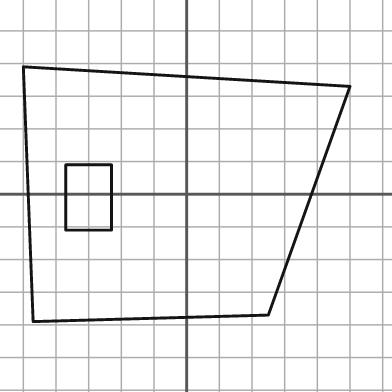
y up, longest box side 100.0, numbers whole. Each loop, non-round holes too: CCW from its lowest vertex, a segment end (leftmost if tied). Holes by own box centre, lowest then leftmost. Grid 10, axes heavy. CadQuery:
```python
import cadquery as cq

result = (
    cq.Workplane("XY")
    .moveTo(-47.0, -39.0)
    .lineTo(25.0, -37.0)
    .lineTo(50.0, 33.0)
    .lineTo(-50.0, 39.0)
    .close()
    .moveTo(-37.0, -11.0)
    .lineTo(-23.0, -11.0)
    .lineTo(-23.0, 9.0)
    .lineTo(-37.0, 9.0)
    .close()
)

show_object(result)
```